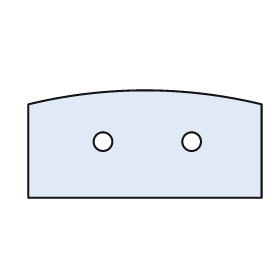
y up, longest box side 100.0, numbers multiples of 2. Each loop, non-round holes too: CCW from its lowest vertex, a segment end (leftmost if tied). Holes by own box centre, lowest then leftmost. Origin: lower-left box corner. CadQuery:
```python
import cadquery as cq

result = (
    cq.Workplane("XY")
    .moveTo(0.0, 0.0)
    .lineTo(100.0, 0.0)
    .lineTo(100.0, 40.0)
    .threePointArc((50.0, 46.0), (0.0, 40.0))
    .close()
    .moveTo(32.0, 24.0)
    .circle(4.0)
    .moveTo(70.0, 24.0)
    .circle(4.0)
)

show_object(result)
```